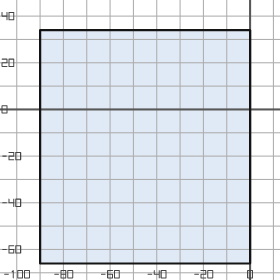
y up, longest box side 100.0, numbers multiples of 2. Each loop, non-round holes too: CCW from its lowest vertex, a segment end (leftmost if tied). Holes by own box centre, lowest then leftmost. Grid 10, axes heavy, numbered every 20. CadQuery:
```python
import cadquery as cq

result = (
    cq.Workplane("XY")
    .moveTo(-90.0, -66.0)
    .lineTo(0.0, -66.0)
    .lineTo(0.0, 34.0)
    .lineTo(-90.0, 34.0)
    .close()
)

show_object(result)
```